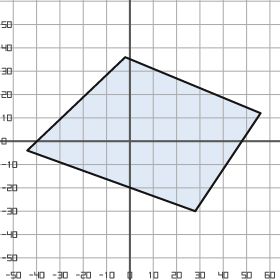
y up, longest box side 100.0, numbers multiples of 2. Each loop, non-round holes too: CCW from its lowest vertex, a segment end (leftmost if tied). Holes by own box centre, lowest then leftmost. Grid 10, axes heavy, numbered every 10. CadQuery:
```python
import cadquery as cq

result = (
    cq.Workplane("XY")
    .moveTo(28.0, -30.0)
    .lineTo(56.0, 12.0)
    .lineTo(-2.0, 36.0)
    .lineTo(-44.0, -4.0)
    .close()
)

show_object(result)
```